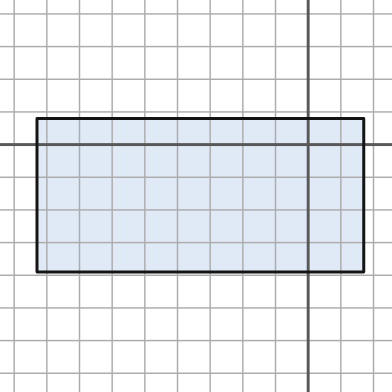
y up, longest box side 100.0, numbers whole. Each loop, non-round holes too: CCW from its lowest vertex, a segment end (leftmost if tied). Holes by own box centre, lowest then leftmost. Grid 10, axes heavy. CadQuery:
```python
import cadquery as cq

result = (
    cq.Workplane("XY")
    .moveTo(-83.0, -39.0)
    .lineTo(17.0, -39.0)
    .lineTo(17.0, 8.0)
    .lineTo(-83.0, 8.0)
    .close()
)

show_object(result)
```